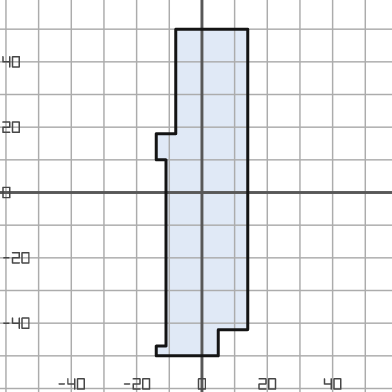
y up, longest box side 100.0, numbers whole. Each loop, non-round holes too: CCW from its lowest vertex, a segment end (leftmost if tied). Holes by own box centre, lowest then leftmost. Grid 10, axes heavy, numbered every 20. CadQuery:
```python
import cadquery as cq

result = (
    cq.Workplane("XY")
    .moveTo(-14.0, -50.0)
    .lineTo(5.0, -50.0)
    .lineTo(5.0, -42.0)
    .lineTo(14.0, -42.0)
    .lineTo(14.0, 50.0)
    .lineTo(-8.0, 50.0)
    .lineTo(-8.0, 18.0)
    .lineTo(-14.0, 18.0)
    .lineTo(-14.0, 10.0)
    .lineTo(-11.0, 10.0)
    .lineTo(-11.0, -47.0)
    .lineTo(-14.0, -47.0)
    .close()
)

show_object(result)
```